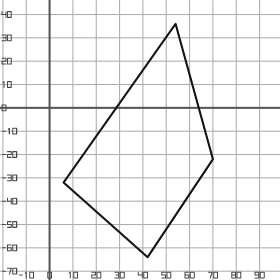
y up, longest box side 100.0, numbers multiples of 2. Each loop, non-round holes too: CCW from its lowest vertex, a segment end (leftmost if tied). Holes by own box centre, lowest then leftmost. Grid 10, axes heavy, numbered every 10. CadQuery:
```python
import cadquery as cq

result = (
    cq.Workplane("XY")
    .moveTo(42.0, -64.0)
    .lineTo(70.0, -22.0)
    .lineTo(54.0, 36.0)
    .lineTo(6.0, -32.0)
    .close()
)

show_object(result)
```